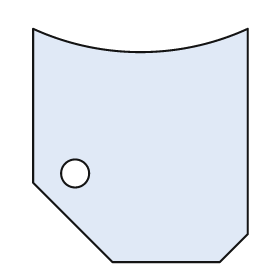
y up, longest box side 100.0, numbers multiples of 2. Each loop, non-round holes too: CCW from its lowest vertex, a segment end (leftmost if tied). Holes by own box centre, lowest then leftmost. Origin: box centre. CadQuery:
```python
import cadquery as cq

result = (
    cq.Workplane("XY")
    .moveTo(-12.0, -50.0)
    .lineTo(34.0, -50.0)
    .lineTo(46.0, -38.0)
    .lineTo(46.0, 50.0)
    .threePointArc((0.0, 40.0), (-46.0, 50.0))
    .lineTo(-46.0, -16.0)
    .close()
    .moveTo(-28.0, -12.0)
    .circle(6.0)
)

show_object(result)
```